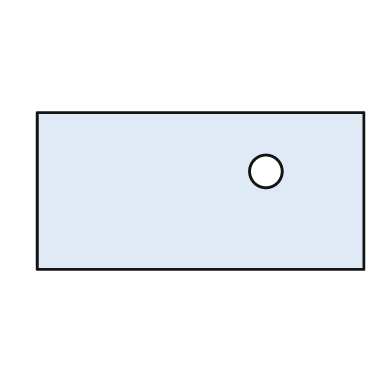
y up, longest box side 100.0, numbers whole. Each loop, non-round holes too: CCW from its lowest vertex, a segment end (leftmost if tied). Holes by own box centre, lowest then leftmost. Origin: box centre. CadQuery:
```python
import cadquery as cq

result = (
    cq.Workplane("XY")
    .moveTo(-50.0, -24.0)
    .lineTo(50.0, -24.0)
    .lineTo(50.0, 24.0)
    .lineTo(-50.0, 24.0)
    .close()
    .moveTo(20.0, 6.0)
    .circle(5.0)
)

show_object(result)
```